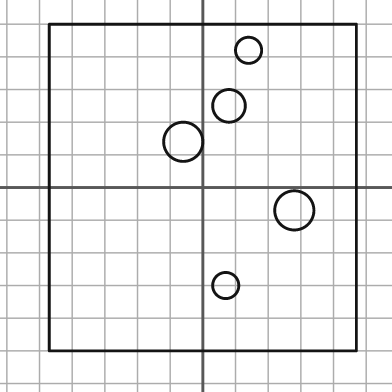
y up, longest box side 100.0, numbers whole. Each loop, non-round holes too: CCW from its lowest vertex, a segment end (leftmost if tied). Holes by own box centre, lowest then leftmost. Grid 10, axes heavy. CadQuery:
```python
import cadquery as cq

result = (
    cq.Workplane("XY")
    .moveTo(-47.0, -50.0)
    .lineTo(47.0, -50.0)
    .lineTo(47.0, 50.0)
    .lineTo(-47.0, 50.0)
    .close()
    .moveTo(7.0, -30.0)
    .circle(4.0)
    .moveTo(28.0, -7.0)
    .circle(6.0)
    .moveTo(-6.0, 14.0)
    .circle(6.0)
    .moveTo(8.0, 25.0)
    .circle(5.0)
    .moveTo(14.0, 42.0)
    .circle(4.0)
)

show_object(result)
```